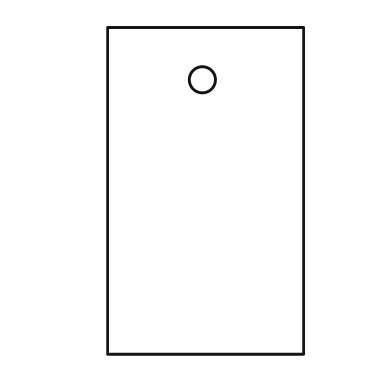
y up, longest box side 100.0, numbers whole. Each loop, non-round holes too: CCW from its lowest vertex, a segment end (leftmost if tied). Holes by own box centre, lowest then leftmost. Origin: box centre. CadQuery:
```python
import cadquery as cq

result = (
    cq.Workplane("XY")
    .moveTo(-30.0, -50.0)
    .lineTo(30.0, -50.0)
    .lineTo(30.0, 50.0)
    .lineTo(-30.0, 50.0)
    .close()
    .moveTo(-1.0, 34.0)
    .circle(4.0)
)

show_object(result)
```